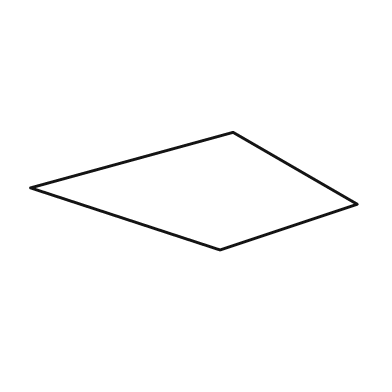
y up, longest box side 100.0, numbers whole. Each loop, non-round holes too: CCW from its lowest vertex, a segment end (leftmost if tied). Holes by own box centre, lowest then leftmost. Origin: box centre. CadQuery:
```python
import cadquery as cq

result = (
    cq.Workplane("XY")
    .moveTo(8.0, -18.0)
    .lineTo(50.0, -4.0)
    .lineTo(12.0, 18.0)
    .lineTo(-50.0, 1.0)
    .close()
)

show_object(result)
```